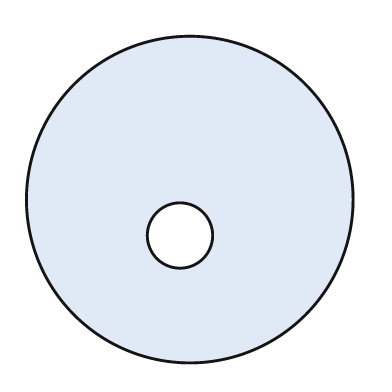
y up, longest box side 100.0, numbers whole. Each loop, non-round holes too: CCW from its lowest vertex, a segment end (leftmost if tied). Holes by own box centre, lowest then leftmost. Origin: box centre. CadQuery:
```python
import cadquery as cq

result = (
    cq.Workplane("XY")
    .moveTo(0.0, 0.0)
    .circle(50.0)
    .moveTo(-3.0, -11.0)
    .circle(10.0)
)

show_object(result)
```